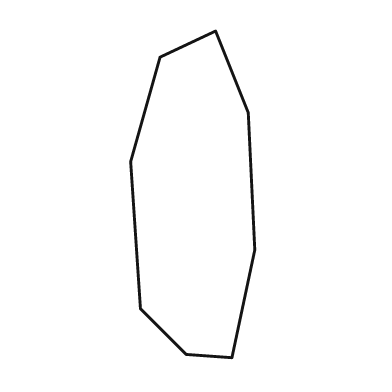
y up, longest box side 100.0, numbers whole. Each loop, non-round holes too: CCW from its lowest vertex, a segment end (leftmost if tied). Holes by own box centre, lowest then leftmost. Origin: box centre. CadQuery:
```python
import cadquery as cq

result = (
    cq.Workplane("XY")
    .moveTo(12.0, -50.0)
    .lineTo(19.0, -17.0)
    .lineTo(17.0, 25.0)
    .lineTo(7.0, 50.0)
    .lineTo(-10.0, 42.0)
    .lineTo(-19.0, 10.0)
    .lineTo(-16.0, -35.0)
    .lineTo(-2.0, -49.0)
    .close()
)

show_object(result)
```